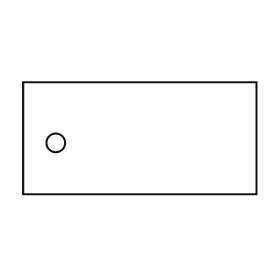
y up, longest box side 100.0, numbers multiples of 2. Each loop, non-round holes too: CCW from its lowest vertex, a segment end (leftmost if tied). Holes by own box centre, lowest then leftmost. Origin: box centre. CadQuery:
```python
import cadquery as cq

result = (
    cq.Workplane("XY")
    .moveTo(-50.0, -24.0)
    .lineTo(50.0, -24.0)
    .lineTo(50.0, 24.0)
    .lineTo(-50.0, 24.0)
    .close()
    .moveTo(-36.0, -2.0)
    .circle(4.0)
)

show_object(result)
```